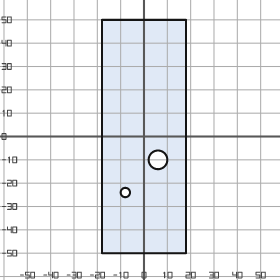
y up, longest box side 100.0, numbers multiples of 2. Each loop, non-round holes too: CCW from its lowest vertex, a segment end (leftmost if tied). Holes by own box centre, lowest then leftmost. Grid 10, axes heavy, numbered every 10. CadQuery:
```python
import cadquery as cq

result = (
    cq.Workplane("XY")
    .moveTo(-18.0, -50.0)
    .lineTo(18.0, -50.0)
    .lineTo(18.0, 50.0)
    .lineTo(-18.0, 50.0)
    .close()
    .moveTo(-8.0, -24.0)
    .circle(2.0)
    .moveTo(6.0, -10.0)
    .circle(4.0)
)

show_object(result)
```